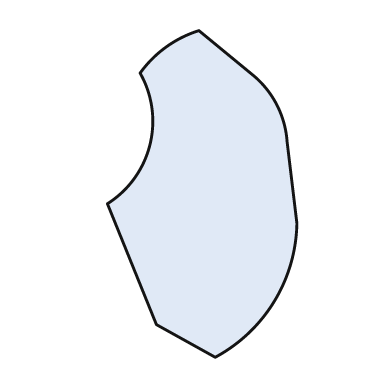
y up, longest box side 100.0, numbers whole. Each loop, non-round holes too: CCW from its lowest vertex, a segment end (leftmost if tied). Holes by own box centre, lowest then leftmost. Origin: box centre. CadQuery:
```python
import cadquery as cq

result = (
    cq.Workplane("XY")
    .moveTo(4.0, -50.0)
    .threePointArc((22.0, -33.0), (29.0, -9.0))
    .lineTo(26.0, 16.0)
    .threePointArc((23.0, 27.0), (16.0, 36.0))
    .lineTo(-1.0, 50.0)
    .threePointArc((-11.0, 45.0), (-19.0, 37.0))
    .threePointArc((-16.0, 15.0), (-29.0, -3.0))
    .lineTo(-14.0, -40.0)
    .close()
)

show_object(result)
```